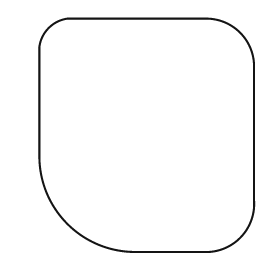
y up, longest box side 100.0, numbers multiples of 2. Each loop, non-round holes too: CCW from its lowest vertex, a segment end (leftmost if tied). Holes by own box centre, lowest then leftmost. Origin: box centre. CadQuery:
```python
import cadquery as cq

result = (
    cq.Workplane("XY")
    .moveTo(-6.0, -50.0)
    .lineTo(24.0, -50.0)
    .threePointArc((40.0, -44.0), (46.0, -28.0))
    .lineTo(46.0, 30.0)
    .threePointArc((40.0, 44.0), (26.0, 50.0))
    .lineTo(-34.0, 50.0)
    .threePointArc((-42.0, 46.0), (-46.0, 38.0))
    .lineTo(-46.0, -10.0)
    .threePointArc((-34.0, -38.0), (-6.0, -50.0))
    .close()
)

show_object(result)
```